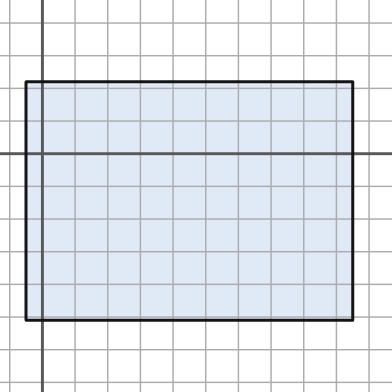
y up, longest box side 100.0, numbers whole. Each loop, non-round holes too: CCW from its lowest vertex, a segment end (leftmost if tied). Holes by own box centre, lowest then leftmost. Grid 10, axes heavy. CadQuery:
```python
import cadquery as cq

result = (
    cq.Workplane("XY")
    .moveTo(-5.0, -51.0)
    .lineTo(95.0, -51.0)
    .lineTo(95.0, 22.0)
    .lineTo(-5.0, 22.0)
    .close()
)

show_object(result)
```